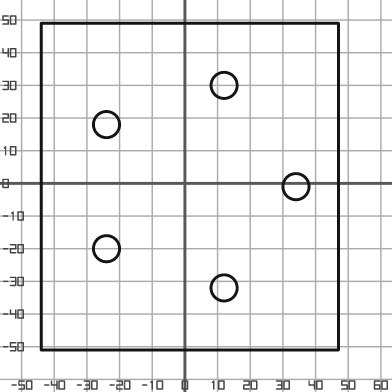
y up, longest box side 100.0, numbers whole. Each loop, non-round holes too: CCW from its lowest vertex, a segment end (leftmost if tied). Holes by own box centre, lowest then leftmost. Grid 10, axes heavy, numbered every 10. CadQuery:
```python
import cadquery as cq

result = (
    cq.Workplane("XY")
    .moveTo(-44.0, -51.0)
    .lineTo(47.0, -51.0)
    .lineTo(47.0, 49.0)
    .lineTo(-44.0, 49.0)
    .close()
    .moveTo(12.0, -32.0)
    .circle(4.0)
    .moveTo(-24.0, -20.0)
    .circle(4.0)
    .moveTo(34.0, -1.0)
    .circle(4.0)
    .moveTo(-24.0, 18.0)
    .circle(4.0)
    .moveTo(12.0, 30.0)
    .circle(4.0)
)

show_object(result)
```